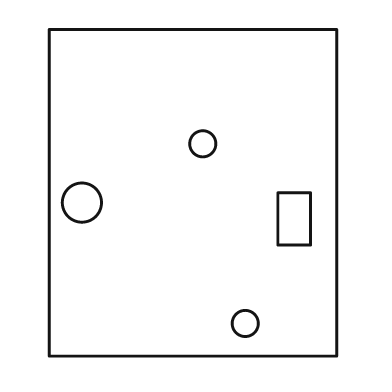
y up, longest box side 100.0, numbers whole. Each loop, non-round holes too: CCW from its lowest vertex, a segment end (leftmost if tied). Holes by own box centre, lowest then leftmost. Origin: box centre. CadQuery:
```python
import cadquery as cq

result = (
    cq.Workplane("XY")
    .moveTo(-44.0, -50.0)
    .lineTo(44.0, -50.0)
    .lineTo(44.0, 50.0)
    .lineTo(-44.0, 50.0)
    .close()
    .moveTo(16.0, -40.0)
    .circle(4.0)
    .moveTo(26.0, -16.0)
    .lineTo(36.0, -16.0)
    .lineTo(36.0, 0.0)
    .lineTo(26.0, 0.0)
    .close()
    .moveTo(-34.0, -3.0)
    .circle(6.0)
    .moveTo(3.0, 15.0)
    .circle(4.0)
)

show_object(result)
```